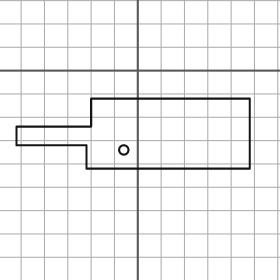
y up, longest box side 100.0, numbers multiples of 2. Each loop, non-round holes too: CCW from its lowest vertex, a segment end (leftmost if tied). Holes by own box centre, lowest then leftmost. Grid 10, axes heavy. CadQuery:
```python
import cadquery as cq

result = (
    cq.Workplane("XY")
    .moveTo(-22.0, -42.0)
    .lineTo(48.0, -42.0)
    .lineTo(48.0, -12.0)
    .lineTo(-20.0, -12.0)
    .lineTo(-20.0, -24.0)
    .lineTo(-52.0, -24.0)
    .lineTo(-52.0, -32.0)
    .lineTo(-22.0, -32.0)
    .close()
    .moveTo(-6.0, -34.0)
    .circle(2.0)
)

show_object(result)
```